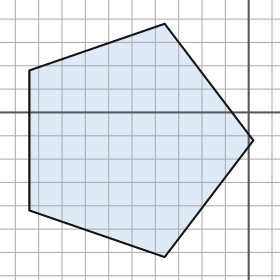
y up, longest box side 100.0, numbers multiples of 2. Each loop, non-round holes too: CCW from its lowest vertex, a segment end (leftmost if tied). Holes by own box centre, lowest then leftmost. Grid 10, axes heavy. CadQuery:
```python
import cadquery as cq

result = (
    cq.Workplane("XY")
    .moveTo(-36.0, -62.0)
    .lineTo(2.0, -12.0)
    .lineTo(-36.0, 38.0)
    .lineTo(-94.0, 18.0)
    .lineTo(-94.0, -42.0)
    .close()
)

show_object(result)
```